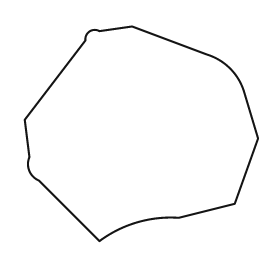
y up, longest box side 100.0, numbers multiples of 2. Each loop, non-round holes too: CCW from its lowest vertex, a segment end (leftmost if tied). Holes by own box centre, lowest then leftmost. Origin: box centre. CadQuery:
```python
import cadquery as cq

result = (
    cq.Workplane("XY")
    .moveTo(-18.0, -46.0)
    .threePointArc((-2.0, -38.0), (16.0, -36.0))
    .lineTo(40.0, -30.0)
    .lineTo(50.0, -2.0)
    .lineTo(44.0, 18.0)
    .threePointArc((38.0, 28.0), (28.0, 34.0))
    .lineTo(-4.0, 46.0)
    .lineTo(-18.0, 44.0)
    .threePointArc((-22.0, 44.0), (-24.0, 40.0))
    .lineTo(-50.0, 6.0)
    .lineTo(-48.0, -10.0)
    .threePointArc((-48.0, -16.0), (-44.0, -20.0))
    .close()
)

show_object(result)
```